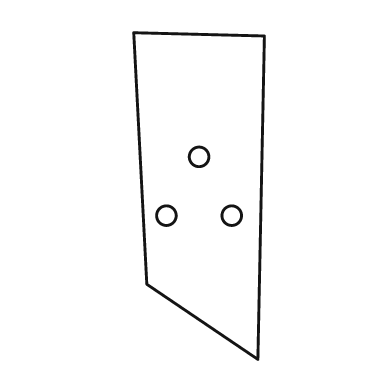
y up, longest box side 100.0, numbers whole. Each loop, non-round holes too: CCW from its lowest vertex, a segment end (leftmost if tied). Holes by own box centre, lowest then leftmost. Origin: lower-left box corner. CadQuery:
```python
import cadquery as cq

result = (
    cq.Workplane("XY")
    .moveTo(38.0, 0.0)
    .lineTo(40.0, 99.0)
    .lineTo(0.0, 100.0)
    .lineTo(4.0, 23.0)
    .close()
    .moveTo(10.0, 44.0)
    .circle(3.0)
    .moveTo(30.0, 44.0)
    .circle(3.0)
    .moveTo(20.0, 62.0)
    .circle(3.0)
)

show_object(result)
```